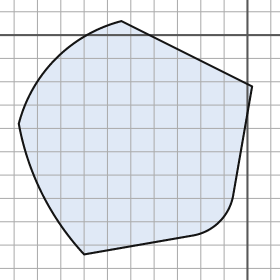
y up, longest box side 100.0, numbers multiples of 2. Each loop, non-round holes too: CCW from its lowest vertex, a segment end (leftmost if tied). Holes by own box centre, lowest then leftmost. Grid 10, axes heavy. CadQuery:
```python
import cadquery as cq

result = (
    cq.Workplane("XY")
    .moveTo(-70.0, -94.0)
    .lineTo(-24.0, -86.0)
    .threePointArc((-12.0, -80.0), (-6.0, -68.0))
    .lineTo(2.0, -22.0)
    .lineTo(-54.0, 6.0)
    .threePointArc((-82.0, -10.0), (-98.0, -38.0))
    .threePointArc((-88.0, -68.0), (-70.0, -94.0))
    .close()
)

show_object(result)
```